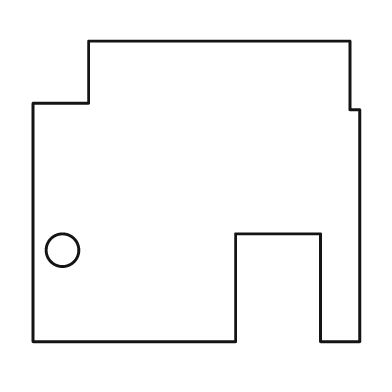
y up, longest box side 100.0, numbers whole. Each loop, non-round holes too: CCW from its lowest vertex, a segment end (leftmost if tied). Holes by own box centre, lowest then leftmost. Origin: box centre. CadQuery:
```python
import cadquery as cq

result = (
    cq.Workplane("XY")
    .moveTo(-50.0, -46.0)
    .lineTo(12.0, -46.0)
    .lineTo(12.0, -13.0)
    .lineTo(38.0, -13.0)
    .lineTo(38.0, -46.0)
    .lineTo(50.0, -46.0)
    .lineTo(50.0, 25.0)
    .lineTo(47.0, 25.0)
    .lineTo(47.0, 46.0)
    .lineTo(-33.0, 46.0)
    .lineTo(-33.0, 27.0)
    .lineTo(-50.0, 27.0)
    .close()
    .moveTo(-41.0, -18.0)
    .circle(5.0)
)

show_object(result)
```